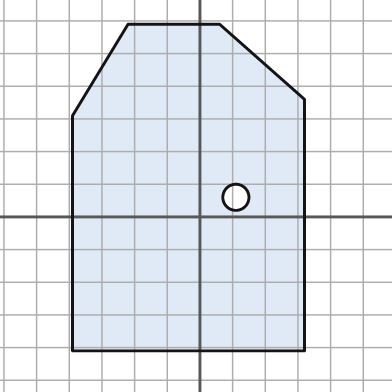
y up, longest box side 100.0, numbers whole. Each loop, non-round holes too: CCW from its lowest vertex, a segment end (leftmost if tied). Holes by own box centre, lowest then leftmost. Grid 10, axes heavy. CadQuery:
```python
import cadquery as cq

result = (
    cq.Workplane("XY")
    .moveTo(-39.0, -41.0)
    .lineTo(32.0, -41.0)
    .lineTo(32.0, 36.0)
    .lineTo(6.0, 59.0)
    .lineTo(-22.0, 59.0)
    .lineTo(-39.0, 31.0)
    .close()
    .moveTo(11.0, 6.0)
    .circle(4.0)
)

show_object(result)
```